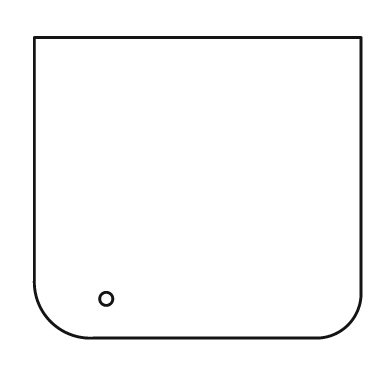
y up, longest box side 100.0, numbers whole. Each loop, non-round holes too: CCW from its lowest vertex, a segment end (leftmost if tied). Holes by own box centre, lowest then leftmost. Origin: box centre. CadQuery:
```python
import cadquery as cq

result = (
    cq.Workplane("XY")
    .moveTo(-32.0, -46.0)
    .lineTo(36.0, -46.0)
    .threePointArc((46.0, -42.0), (50.0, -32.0))
    .lineTo(50.0, 46.0)
    .lineTo(-50.0, 46.0)
    .lineTo(-50.0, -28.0)
    .threePointArc((-45.0, -41.0), (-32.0, -46.0))
    .close()
    .moveTo(-28.0, -34.0)
    .circle(2.0)
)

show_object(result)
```